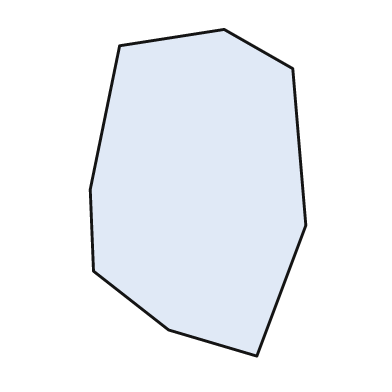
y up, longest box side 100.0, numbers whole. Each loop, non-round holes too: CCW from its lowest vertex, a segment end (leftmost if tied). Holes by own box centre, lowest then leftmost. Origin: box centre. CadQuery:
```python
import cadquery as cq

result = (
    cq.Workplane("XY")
    .moveTo(18.0, -50.0)
    .lineTo(33.0, -10.0)
    .lineTo(29.0, 38.0)
    .lineTo(8.0, 50.0)
    .lineTo(-24.0, 45.0)
    .lineTo(-33.0, 1.0)
    .lineTo(-32.0, -24.0)
    .lineTo(-9.0, -42.0)
    .close()
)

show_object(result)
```